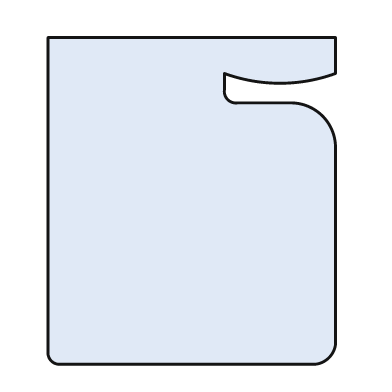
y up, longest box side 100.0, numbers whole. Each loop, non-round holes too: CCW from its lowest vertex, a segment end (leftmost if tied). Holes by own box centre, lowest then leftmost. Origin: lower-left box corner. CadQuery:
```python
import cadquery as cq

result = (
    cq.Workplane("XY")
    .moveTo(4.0, 0.0)
    .lineTo(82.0, 0.0)
    .threePointArc((86.0, 2.0), (88.0, 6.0))
    .lineTo(88.0, 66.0)
    .threePointArc((84.0, 76.0), (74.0, 80.0))
    .lineTo(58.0, 80.0)
    .threePointArc((55.0, 81.0), (54.0, 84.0))
    .lineTo(54.0, 89.0)
    .threePointArc((71.0, 86.0), (88.0, 89.0))
    .lineTo(88.0, 100.0)
    .lineTo(0.0, 100.0)
    .lineTo(0.0, 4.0)
    .threePointArc((1.0, 1.0), (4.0, 0.0))
    .close()
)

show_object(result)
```